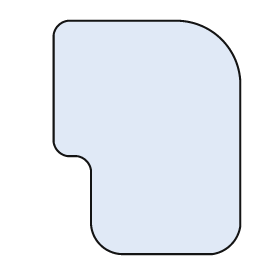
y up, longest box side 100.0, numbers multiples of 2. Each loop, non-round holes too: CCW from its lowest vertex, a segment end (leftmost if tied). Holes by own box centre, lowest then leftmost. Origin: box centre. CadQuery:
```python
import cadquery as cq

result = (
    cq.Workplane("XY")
    .moveTo(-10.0, -50.0)
    .lineTo(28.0, -50.0)
    .threePointArc((36.0, -46.0), (40.0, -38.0))
    .lineTo(40.0, 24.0)
    .threePointArc((32.0, 42.0), (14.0, 50.0))
    .lineTo(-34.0, 50.0)
    .threePointArc((-38.0, 48.0), (-40.0, 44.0))
    .lineTo(-40.0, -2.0)
    .threePointArc((-38.0, -6.0), (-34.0, -8.0))
    .lineTo(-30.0, -8.0)
    .threePointArc((-26.0, -10.0), (-24.0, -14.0))
    .lineTo(-24.0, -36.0)
    .threePointArc((-20.0, -46.0), (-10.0, -50.0))
    .close()
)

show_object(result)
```